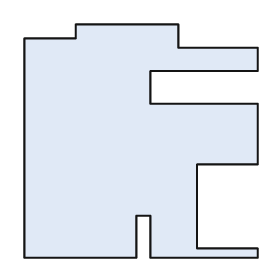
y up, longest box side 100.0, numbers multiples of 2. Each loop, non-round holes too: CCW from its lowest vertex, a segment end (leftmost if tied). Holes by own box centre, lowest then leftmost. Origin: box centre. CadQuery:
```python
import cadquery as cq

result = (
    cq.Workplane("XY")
    .moveTo(-50.0, -50.0)
    .lineTo(-2.0, -50.0)
    .lineTo(-2.0, -32.0)
    .lineTo(4.0, -32.0)
    .lineTo(4.0, -50.0)
    .lineTo(50.0, -50.0)
    .lineTo(50.0, -46.0)
    .lineTo(24.0, -46.0)
    .lineTo(24.0, -10.0)
    .lineTo(50.0, -10.0)
    .lineTo(50.0, 16.0)
    .lineTo(4.0, 16.0)
    .lineTo(4.0, 30.0)
    .lineTo(50.0, 30.0)
    .lineTo(50.0, 40.0)
    .lineTo(16.0, 40.0)
    .lineTo(16.0, 50.0)
    .lineTo(-28.0, 50.0)
    .lineTo(-28.0, 44.0)
    .lineTo(-50.0, 44.0)
    .close()
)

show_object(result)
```